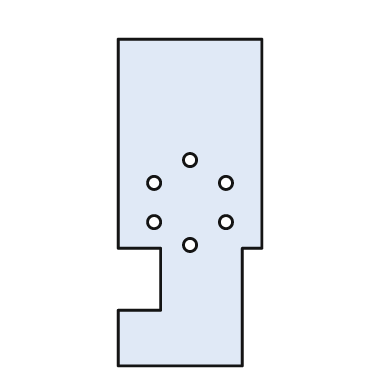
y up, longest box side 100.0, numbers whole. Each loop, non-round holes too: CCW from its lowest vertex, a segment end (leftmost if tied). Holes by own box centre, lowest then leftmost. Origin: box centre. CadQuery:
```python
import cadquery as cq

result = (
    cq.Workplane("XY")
    .moveTo(-22.0, -50.0)
    .lineTo(16.0, -50.0)
    .lineTo(16.0, -14.0)
    .lineTo(22.0, -14.0)
    .lineTo(22.0, 50.0)
    .lineTo(-22.0, 50.0)
    .lineTo(-22.0, -14.0)
    .lineTo(-9.0, -14.0)
    .lineTo(-9.0, -33.0)
    .lineTo(-22.0, -33.0)
    .close()
    .moveTo(0.0, -13.0)
    .circle(2.0)
    .moveTo(-11.0, -6.0)
    .circle(2.0)
    .moveTo(11.0, -6.0)
    .circle(2.0)
    .moveTo(-11.0, 6.0)
    .circle(2.0)
    .moveTo(11.0, 6.0)
    .circle(2.0)
    .moveTo(0.0, 13.0)
    .circle(2.0)
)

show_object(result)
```